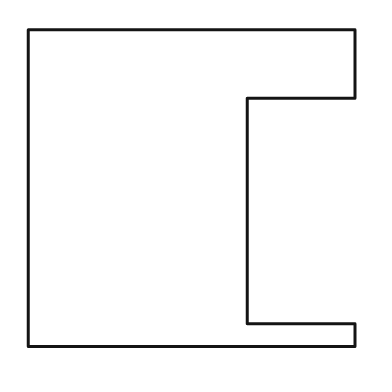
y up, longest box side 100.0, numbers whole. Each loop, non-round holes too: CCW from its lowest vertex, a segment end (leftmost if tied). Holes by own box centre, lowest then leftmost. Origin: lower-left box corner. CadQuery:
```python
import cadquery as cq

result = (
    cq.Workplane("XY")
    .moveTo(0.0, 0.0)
    .lineTo(100.0, 0.0)
    .lineTo(100.0, 7.0)
    .lineTo(67.0, 7.0)
    .lineTo(67.0, 76.0)
    .lineTo(100.0, 76.0)
    .lineTo(100.0, 97.0)
    .lineTo(0.0, 97.0)
    .close()
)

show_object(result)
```